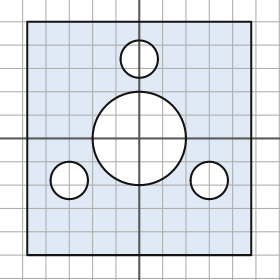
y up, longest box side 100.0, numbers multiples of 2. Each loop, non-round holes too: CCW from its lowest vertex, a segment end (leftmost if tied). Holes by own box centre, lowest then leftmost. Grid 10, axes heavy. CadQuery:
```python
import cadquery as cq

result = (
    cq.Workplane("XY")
    .moveTo(-48.0, -50.0)
    .lineTo(48.0, -50.0)
    .lineTo(48.0, 50.0)
    .lineTo(-48.0, 50.0)
    .close()
    .moveTo(-30.0, -18.0)
    .circle(8.0)
    .moveTo(30.0, -18.0)
    .circle(8.0)
    .moveTo(0.0, 0.0)
    .circle(20.0)
    .moveTo(0.0, 34.0)
    .circle(8.0)
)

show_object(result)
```